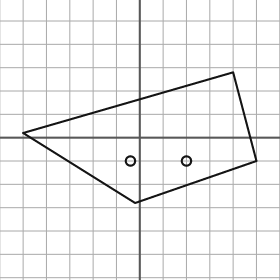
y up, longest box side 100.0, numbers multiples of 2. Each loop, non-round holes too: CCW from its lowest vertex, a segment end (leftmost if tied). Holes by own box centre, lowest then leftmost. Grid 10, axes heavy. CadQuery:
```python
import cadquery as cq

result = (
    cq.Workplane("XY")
    .moveTo(-2.0, -28.0)
    .lineTo(50.0, -10.0)
    .lineTo(40.0, 28.0)
    .lineTo(-50.0, 2.0)
    .close()
    .moveTo(-4.0, -10.0)
    .circle(2.0)
    .moveTo(20.0, -10.0)
    .circle(2.0)
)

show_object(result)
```